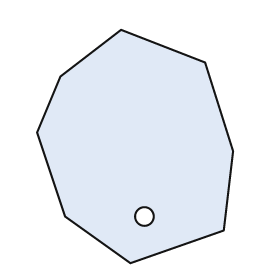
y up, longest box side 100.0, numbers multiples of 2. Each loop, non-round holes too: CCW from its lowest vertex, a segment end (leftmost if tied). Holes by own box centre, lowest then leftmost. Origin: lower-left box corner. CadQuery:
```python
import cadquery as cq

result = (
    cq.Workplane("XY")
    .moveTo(40.0, 0.0)
    .lineTo(80.0, 14.0)
    .lineTo(84.0, 48.0)
    .lineTo(72.0, 86.0)
    .lineTo(36.0, 100.0)
    .lineTo(10.0, 80.0)
    .lineTo(0.0, 56.0)
    .lineTo(12.0, 20.0)
    .close()
    .moveTo(46.0, 20.0)
    .circle(4.0)
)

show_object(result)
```